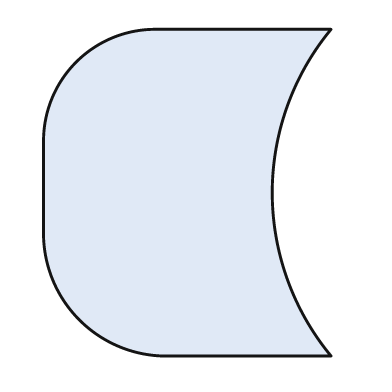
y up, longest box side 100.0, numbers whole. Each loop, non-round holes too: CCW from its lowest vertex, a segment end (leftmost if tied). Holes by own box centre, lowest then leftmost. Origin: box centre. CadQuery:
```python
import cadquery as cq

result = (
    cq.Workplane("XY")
    .moveTo(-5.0, -50.0)
    .lineTo(44.0, -50.0)
    .threePointArc((26.0, 0.0), (44.0, 50.0))
    .lineTo(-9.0, 50.0)
    .threePointArc((-34.0, 40.0), (-44.0, 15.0))
    .lineTo(-44.0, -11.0)
    .threePointArc((-33.0, -39.0), (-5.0, -50.0))
    .close()
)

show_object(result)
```